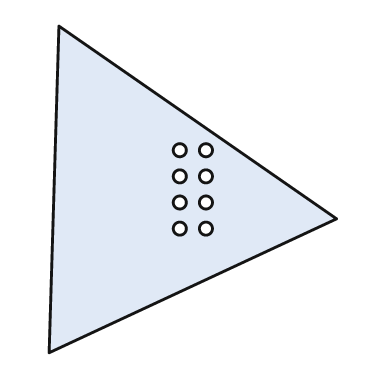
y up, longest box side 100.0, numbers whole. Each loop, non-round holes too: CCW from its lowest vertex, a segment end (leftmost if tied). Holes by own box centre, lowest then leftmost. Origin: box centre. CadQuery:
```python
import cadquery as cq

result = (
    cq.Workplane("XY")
    .moveTo(-44.0, -50.0)
    .lineTo(44.0, -9.0)
    .lineTo(-41.0, 50.0)
    .close()
    .moveTo(-4.0, -12.0)
    .circle(2.0)
    .moveTo(4.0, -12.0)
    .circle(2.0)
    .moveTo(-4.0, -4.0)
    .circle(2.0)
    .moveTo(4.0, -4.0)
    .circle(2.0)
    .moveTo(-4.0, 4.0)
    .circle(2.0)
    .moveTo(4.0, 4.0)
    .circle(2.0)
    .moveTo(-4.0, 12.0)
    .circle(2.0)
    .moveTo(4.0, 12.0)
    .circle(2.0)
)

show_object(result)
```